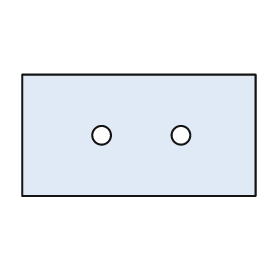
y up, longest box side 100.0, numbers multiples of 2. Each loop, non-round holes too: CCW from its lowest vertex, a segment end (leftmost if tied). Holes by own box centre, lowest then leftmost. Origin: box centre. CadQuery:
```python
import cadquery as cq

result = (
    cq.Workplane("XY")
    .moveTo(-50.0, -26.0)
    .lineTo(50.0, -26.0)
    .lineTo(50.0, 26.0)
    .lineTo(-50.0, 26.0)
    .close()
    .moveTo(-16.0, 0.0)
    .circle(4.0)
    .moveTo(18.0, 0.0)
    .circle(4.0)
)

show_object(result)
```